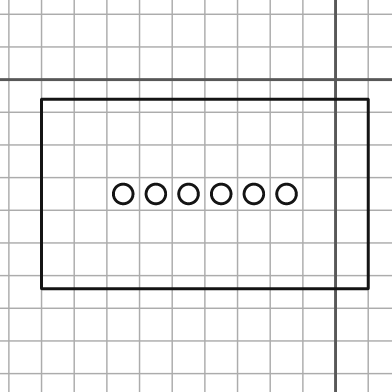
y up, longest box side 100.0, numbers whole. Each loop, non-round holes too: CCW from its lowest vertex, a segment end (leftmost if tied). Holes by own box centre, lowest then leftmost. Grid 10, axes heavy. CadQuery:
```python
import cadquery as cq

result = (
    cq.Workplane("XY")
    .moveTo(-90.0, -64.0)
    .lineTo(10.0, -64.0)
    .lineTo(10.0, -6.0)
    .lineTo(-90.0, -6.0)
    .close()
    .moveTo(-65.0, -35.0)
    .circle(3.0)
    .moveTo(-55.0, -35.0)
    .circle(3.0)
    .moveTo(-45.0, -35.0)
    .circle(3.0)
    .moveTo(-35.0, -35.0)
    .circle(3.0)
    .moveTo(-25.0, -35.0)
    .circle(3.0)
    .moveTo(-15.0, -35.0)
    .circle(3.0)
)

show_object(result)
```